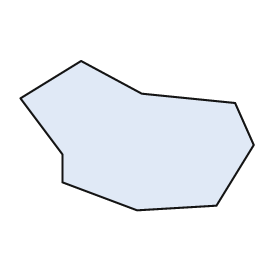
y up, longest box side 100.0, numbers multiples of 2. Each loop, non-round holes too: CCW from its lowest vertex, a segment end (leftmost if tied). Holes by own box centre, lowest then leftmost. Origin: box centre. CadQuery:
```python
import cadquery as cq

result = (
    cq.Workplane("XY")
    .moveTo(0.0, -32.0)
    .lineTo(34.0, -30.0)
    .lineTo(50.0, -4.0)
    .lineTo(42.0, 14.0)
    .lineTo(2.0, 18.0)
    .lineTo(-24.0, 32.0)
    .lineTo(-50.0, 16.0)
    .lineTo(-32.0, -8.0)
    .lineTo(-32.0, -20.0)
    .close()
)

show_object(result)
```